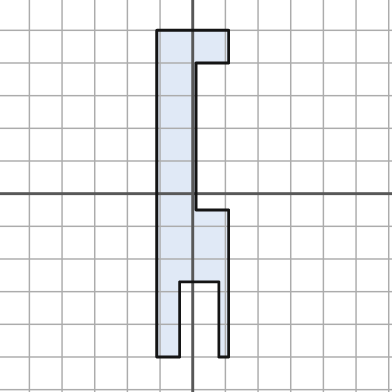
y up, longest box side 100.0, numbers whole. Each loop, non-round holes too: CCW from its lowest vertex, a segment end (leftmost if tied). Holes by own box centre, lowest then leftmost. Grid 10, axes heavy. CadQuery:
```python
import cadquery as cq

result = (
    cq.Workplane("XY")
    .moveTo(-11.0, -50.0)
    .lineTo(-4.0, -50.0)
    .lineTo(-4.0, -27.0)
    .lineTo(8.0, -27.0)
    .lineTo(8.0, -50.0)
    .lineTo(11.0, -50.0)
    .lineTo(11.0, -5.0)
    .lineTo(1.0, -5.0)
    .lineTo(1.0, 40.0)
    .lineTo(11.0, 40.0)
    .lineTo(11.0, 50.0)
    .lineTo(-11.0, 50.0)
    .close()
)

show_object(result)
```